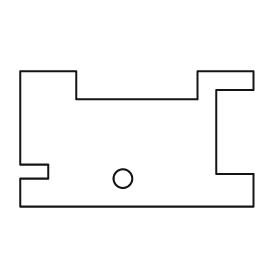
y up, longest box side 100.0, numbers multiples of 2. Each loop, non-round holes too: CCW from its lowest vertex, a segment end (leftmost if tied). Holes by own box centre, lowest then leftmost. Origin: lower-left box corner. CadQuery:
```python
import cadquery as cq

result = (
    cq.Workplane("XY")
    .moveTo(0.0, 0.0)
    .lineTo(100.0, 0.0)
    .lineTo(100.0, 14.0)
    .lineTo(84.0, 14.0)
    .lineTo(84.0, 50.0)
    .lineTo(100.0, 50.0)
    .lineTo(100.0, 58.0)
    .lineTo(76.0, 58.0)
    .lineTo(76.0, 46.0)
    .lineTo(24.0, 46.0)
    .lineTo(24.0, 58.0)
    .lineTo(0.0, 58.0)
    .lineTo(0.0, 18.0)
    .lineTo(12.0, 18.0)
    .lineTo(12.0, 12.0)
    .lineTo(0.0, 12.0)
    .close()
    .moveTo(44.0, 12.0)
    .circle(4.0)
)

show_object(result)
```